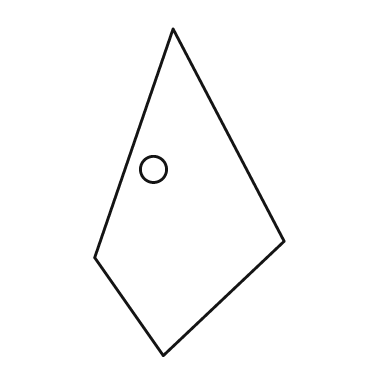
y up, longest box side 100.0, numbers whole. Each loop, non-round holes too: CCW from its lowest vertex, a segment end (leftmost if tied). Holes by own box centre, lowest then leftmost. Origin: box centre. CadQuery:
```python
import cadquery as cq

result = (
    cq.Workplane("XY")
    .moveTo(-8.0, -50.0)
    .lineTo(29.0, -15.0)
    .lineTo(-5.0, 50.0)
    .lineTo(-29.0, -20.0)
    .close()
    .moveTo(-11.0, 7.0)
    .circle(4.0)
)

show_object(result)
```